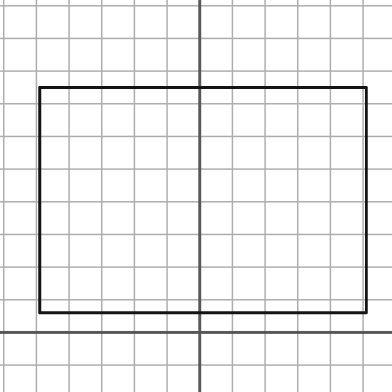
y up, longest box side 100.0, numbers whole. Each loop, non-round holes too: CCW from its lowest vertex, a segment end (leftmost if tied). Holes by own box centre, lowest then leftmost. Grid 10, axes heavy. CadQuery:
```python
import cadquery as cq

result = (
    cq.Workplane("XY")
    .moveTo(-49.0, 6.0)
    .lineTo(51.0, 6.0)
    .lineTo(51.0, 75.0)
    .lineTo(-49.0, 75.0)
    .close()
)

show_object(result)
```